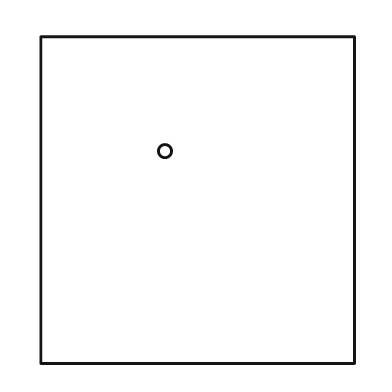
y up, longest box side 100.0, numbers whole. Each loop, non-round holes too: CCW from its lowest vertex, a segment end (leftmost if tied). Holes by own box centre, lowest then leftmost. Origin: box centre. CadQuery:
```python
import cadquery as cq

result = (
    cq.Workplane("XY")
    .moveTo(-48.0, -50.0)
    .lineTo(48.0, -50.0)
    .lineTo(48.0, 50.0)
    .lineTo(-48.0, 50.0)
    .close()
    .moveTo(-10.0, 15.0)
    .circle(2.0)
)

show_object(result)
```